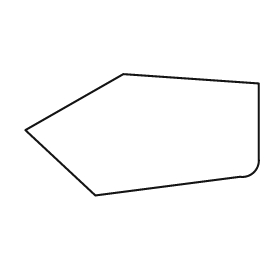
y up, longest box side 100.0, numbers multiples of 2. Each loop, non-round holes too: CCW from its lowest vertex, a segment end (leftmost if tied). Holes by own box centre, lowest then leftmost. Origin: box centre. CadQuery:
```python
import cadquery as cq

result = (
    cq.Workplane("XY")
    .moveTo(-20.0, -26.0)
    .lineTo(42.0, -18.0)
    .threePointArc((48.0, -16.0), (50.0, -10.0))
    .lineTo(50.0, 22.0)
    .lineTo(-8.0, 26.0)
    .lineTo(-50.0, 2.0)
    .close()
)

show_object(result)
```